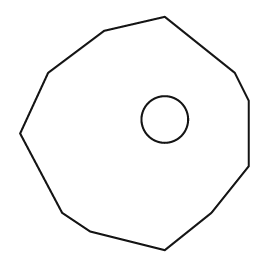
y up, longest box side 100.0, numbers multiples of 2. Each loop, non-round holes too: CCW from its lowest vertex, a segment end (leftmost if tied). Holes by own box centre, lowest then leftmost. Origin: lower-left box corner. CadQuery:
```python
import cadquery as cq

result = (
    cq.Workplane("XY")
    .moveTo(62.0, 0.0)
    .lineTo(82.0, 16.0)
    .lineTo(98.0, 36.0)
    .lineTo(98.0, 64.0)
    .lineTo(92.0, 76.0)
    .lineTo(62.0, 100.0)
    .lineTo(36.0, 94.0)
    .lineTo(12.0, 76.0)
    .lineTo(0.0, 50.0)
    .lineTo(18.0, 16.0)
    .lineTo(30.0, 8.0)
    .close()
    .moveTo(62.0, 56.0)
    .circle(10.0)
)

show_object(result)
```